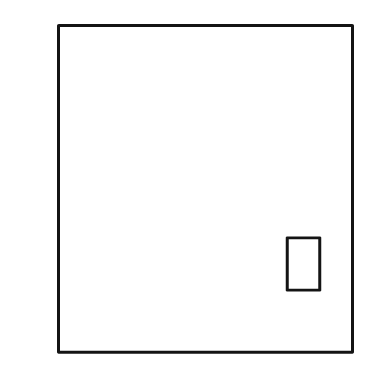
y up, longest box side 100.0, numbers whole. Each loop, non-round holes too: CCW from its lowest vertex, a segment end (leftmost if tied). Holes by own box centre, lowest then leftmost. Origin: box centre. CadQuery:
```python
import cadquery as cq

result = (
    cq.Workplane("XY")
    .moveTo(-45.0, -50.0)
    .lineTo(45.0, -50.0)
    .lineTo(45.0, 50.0)
    .lineTo(-45.0, 50.0)
    .close()
    .moveTo(25.0, -31.0)
    .lineTo(35.0, -31.0)
    .lineTo(35.0, -15.0)
    .lineTo(25.0, -15.0)
    .close()
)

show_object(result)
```